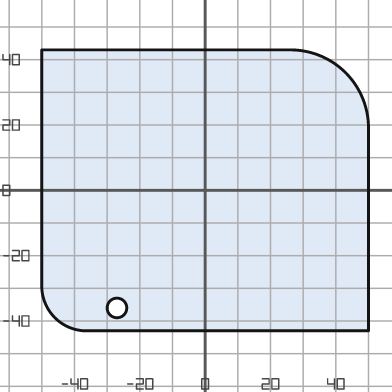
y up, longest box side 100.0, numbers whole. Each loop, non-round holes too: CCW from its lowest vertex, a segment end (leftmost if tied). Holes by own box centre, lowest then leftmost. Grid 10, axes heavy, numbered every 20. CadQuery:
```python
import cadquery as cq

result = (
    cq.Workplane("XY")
    .moveTo(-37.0, -43.0)
    .lineTo(50.0, -43.0)
    .lineTo(50.0, 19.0)
    .threePointArc((43.0, 36.0), (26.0, 43.0))
    .lineTo(-50.0, 43.0)
    .lineTo(-50.0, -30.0)
    .threePointArc((-46.0, -39.0), (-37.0, -43.0))
    .close()
    .moveTo(-27.0, -36.0)
    .circle(3.0)
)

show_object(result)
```